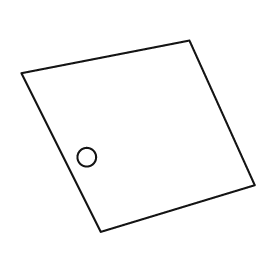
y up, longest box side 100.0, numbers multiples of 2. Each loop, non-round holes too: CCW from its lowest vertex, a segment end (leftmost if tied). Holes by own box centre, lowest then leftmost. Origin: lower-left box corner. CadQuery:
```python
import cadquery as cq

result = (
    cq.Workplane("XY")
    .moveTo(34.0, 0.0)
    .lineTo(100.0, 20.0)
    .lineTo(72.0, 82.0)
    .lineTo(0.0, 68.0)
    .close()
    .moveTo(28.0, 32.0)
    .circle(4.0)
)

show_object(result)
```